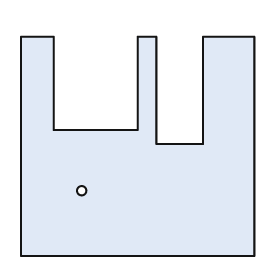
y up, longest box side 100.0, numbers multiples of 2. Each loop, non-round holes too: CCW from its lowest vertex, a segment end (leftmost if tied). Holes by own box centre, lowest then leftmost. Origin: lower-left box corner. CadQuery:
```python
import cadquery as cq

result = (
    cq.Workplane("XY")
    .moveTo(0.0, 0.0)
    .lineTo(100.0, 0.0)
    .lineTo(100.0, 94.0)
    .lineTo(78.0, 94.0)
    .lineTo(78.0, 48.0)
    .lineTo(58.0, 48.0)
    .lineTo(58.0, 94.0)
    .lineTo(50.0, 94.0)
    .lineTo(50.0, 54.0)
    .lineTo(14.0, 54.0)
    .lineTo(14.0, 94.0)
    .lineTo(0.0, 94.0)
    .close()
    .moveTo(26.0, 28.0)
    .circle(2.0)
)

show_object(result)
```